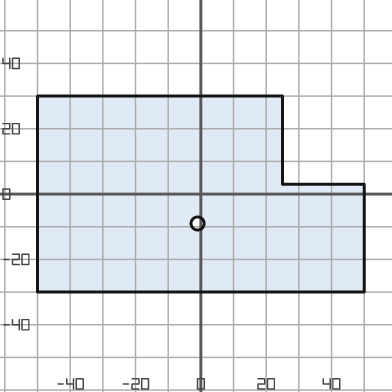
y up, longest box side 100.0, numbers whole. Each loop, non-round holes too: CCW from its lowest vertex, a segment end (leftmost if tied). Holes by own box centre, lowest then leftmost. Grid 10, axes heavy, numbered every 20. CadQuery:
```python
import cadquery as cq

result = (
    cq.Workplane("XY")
    .moveTo(-50.0, -30.0)
    .lineTo(50.0, -30.0)
    .lineTo(50.0, 3.0)
    .lineTo(25.0, 3.0)
    .lineTo(25.0, 30.0)
    .lineTo(-50.0, 30.0)
    .close()
    .moveTo(-1.0, -9.0)
    .circle(2.0)
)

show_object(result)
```